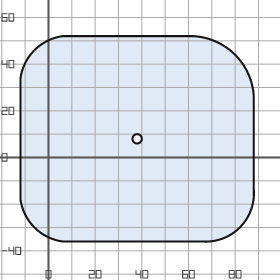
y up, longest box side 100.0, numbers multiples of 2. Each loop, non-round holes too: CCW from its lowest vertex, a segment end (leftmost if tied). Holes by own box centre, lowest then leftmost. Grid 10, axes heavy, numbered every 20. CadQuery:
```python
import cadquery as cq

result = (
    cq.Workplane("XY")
    .moveTo(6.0, -36.0)
    .lineTo(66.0, -36.0)
    .threePointArc((82.0, -30.0), (88.0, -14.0))
    .lineTo(88.0, 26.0)
    .threePointArc((80.0, 44.0), (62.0, 52.0))
    .lineTo(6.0, 52.0)
    .threePointArc((-6.0, 46.0), (-12.0, 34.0))
    .lineTo(-12.0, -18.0)
    .threePointArc((-6.0, -30.0), (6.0, -36.0))
    .close()
    .moveTo(38.0, 8.0)
    .circle(2.0)
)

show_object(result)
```